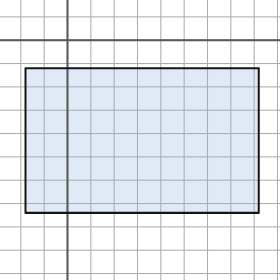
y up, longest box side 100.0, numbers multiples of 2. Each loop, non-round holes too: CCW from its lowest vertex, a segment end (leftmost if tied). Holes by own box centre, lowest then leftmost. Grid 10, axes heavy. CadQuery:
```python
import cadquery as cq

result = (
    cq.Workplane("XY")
    .moveTo(-18.0, -74.0)
    .lineTo(82.0, -74.0)
    .lineTo(82.0, -12.0)
    .lineTo(-18.0, -12.0)
    .close()
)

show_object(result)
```